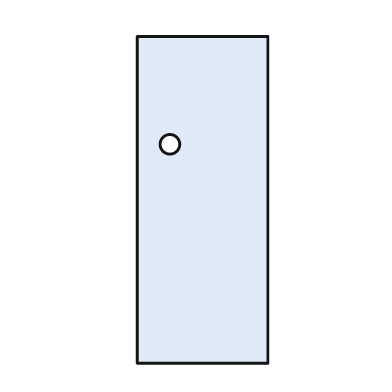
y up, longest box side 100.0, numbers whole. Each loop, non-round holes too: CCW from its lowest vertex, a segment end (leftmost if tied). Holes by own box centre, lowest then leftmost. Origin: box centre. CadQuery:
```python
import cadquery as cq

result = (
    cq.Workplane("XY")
    .moveTo(-20.0, -50.0)
    .lineTo(20.0, -50.0)
    .lineTo(20.0, 50.0)
    .lineTo(-20.0, 50.0)
    .close()
    .moveTo(-10.0, 17.0)
    .circle(3.0)
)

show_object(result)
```